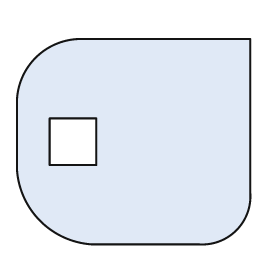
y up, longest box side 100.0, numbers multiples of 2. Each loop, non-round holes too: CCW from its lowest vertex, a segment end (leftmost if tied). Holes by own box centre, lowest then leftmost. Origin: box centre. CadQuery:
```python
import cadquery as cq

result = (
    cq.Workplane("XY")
    .moveTo(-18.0, -44.0)
    .lineTo(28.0, -44.0)
    .threePointArc((44.0, -38.0), (50.0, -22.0))
    .lineTo(50.0, 44.0)
    .lineTo(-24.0, 44.0)
    .threePointArc((-42.0, 36.0), (-50.0, 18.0))
    .lineTo(-50.0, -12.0)
    .threePointArc((-40.0, -34.0), (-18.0, -44.0))
    .close()
    .moveTo(-36.0, -10.0)
    .lineTo(-16.0, -10.0)
    .lineTo(-16.0, 10.0)
    .lineTo(-36.0, 10.0)
    .close()
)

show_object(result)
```